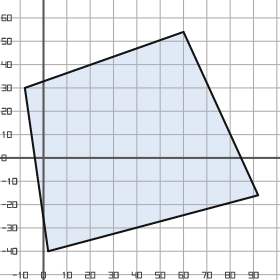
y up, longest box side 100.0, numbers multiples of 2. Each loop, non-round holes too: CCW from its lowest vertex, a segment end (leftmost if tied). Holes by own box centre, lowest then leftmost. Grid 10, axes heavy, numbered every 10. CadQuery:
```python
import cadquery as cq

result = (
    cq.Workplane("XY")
    .moveTo(2.0, -40.0)
    .lineTo(92.0, -16.0)
    .lineTo(60.0, 54.0)
    .lineTo(-8.0, 30.0)
    .close()
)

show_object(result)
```